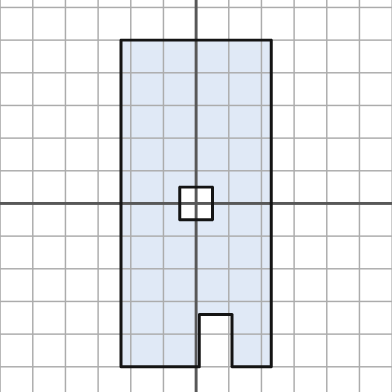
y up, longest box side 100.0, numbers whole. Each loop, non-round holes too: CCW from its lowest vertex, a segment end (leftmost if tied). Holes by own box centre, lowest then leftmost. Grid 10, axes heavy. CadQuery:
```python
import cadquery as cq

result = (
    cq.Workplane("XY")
    .moveTo(-23.0, -50.0)
    .lineTo(1.0, -50.0)
    .lineTo(1.0, -34.0)
    .lineTo(11.0, -34.0)
    .lineTo(11.0, -50.0)
    .lineTo(23.0, -50.0)
    .lineTo(23.0, 50.0)
    .lineTo(-23.0, 50.0)
    .close()
    .moveTo(-5.0, -5.0)
    .lineTo(5.0, -5.0)
    .lineTo(5.0, 5.0)
    .lineTo(-5.0, 5.0)
    .close()
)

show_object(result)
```